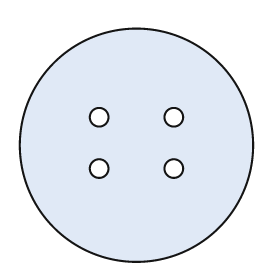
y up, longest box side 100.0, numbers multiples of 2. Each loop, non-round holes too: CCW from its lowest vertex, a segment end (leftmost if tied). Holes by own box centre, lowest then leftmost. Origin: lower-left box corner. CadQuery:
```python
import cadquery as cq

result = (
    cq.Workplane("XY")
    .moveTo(50.0, 50.0)
    .circle(50.0)
    .moveTo(34.0, 40.0)
    .circle(4.0)
    .moveTo(66.0, 40.0)
    .circle(4.0)
    .moveTo(34.0, 62.0)
    .circle(4.0)
    .moveTo(66.0, 62.0)
    .circle(4.0)
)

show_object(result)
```